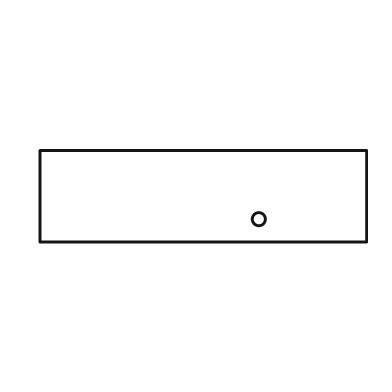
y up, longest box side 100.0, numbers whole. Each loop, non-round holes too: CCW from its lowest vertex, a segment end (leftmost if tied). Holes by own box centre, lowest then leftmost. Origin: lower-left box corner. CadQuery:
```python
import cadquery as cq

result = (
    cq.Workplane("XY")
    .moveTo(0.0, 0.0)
    .lineTo(100.0, 0.0)
    .lineTo(100.0, 28.0)
    .lineTo(0.0, 28.0)
    .close()
    .moveTo(67.0, 7.0)
    .circle(2.0)
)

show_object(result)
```